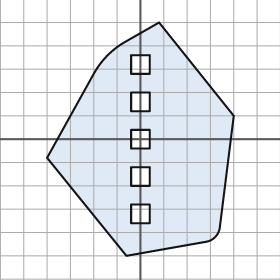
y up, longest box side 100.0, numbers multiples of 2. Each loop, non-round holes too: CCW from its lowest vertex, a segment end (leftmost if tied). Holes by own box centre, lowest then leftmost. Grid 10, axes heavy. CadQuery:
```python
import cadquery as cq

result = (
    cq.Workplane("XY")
    .moveTo(-6.0, -50.0)
    .lineTo(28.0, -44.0)
    .threePointArc((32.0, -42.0), (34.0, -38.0))
    .lineTo(40.0, 10.0)
    .lineTo(8.0, 50.0)
    .lineTo(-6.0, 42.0)
    .threePointArc((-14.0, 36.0), (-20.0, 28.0))
    .lineTo(-40.0, -8.0)
    .close()
    .moveTo(-4.0, -36.0)
    .lineTo(4.0, -36.0)
    .lineTo(4.0, -28.0)
    .lineTo(-4.0, -28.0)
    .close()
    .moveTo(-4.0, -20.0)
    .lineTo(4.0, -20.0)
    .lineTo(4.0, -12.0)
    .lineTo(-4.0, -12.0)
    .close()
    .moveTo(-4.0, -4.0)
    .lineTo(4.0, -4.0)
    .lineTo(4.0, 4.0)
    .lineTo(-4.0, 4.0)
    .close()
    .moveTo(-4.0, 12.0)
    .lineTo(4.0, 12.0)
    .lineTo(4.0, 20.0)
    .lineTo(-4.0, 20.0)
    .close()
    .moveTo(-4.0, 28.0)
    .lineTo(4.0, 28.0)
    .lineTo(4.0, 36.0)
    .lineTo(-4.0, 36.0)
    .close()
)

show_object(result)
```